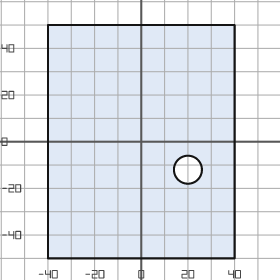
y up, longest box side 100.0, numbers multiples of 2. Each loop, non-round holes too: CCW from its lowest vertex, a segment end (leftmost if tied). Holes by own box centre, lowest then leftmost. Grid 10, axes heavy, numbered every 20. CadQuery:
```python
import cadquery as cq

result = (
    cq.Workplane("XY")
    .moveTo(-40.0, -50.0)
    .lineTo(40.0, -50.0)
    .lineTo(40.0, 50.0)
    .lineTo(-40.0, 50.0)
    .close()
    .moveTo(20.0, -12.0)
    .circle(6.0)
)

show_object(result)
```